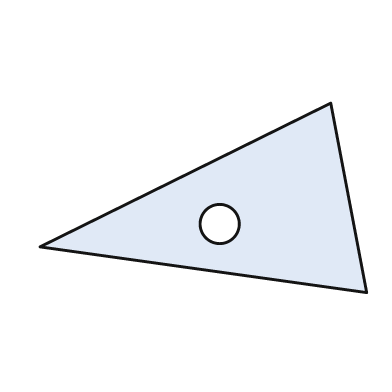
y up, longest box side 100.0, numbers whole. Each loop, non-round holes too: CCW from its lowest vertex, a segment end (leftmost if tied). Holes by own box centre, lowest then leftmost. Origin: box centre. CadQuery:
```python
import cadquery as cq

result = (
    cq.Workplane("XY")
    .moveTo(50.0, -29.0)
    .lineTo(39.0, 29.0)
    .lineTo(-50.0, -15.0)
    .close()
    .moveTo(5.0, -8.0)
    .circle(6.0)
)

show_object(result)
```